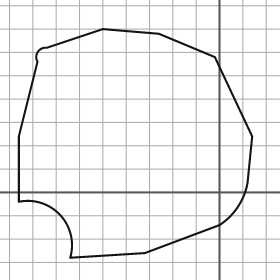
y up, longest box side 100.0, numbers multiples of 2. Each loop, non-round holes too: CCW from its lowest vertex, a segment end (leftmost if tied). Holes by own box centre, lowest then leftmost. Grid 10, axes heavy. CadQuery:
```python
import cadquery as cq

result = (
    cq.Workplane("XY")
    .moveTo(-64.0, -28.0)
    .lineTo(-32.0, -26.0)
    .lineTo(0.0, -14.0)
    .threePointArc((8.0, -6.0), (12.0, 4.0))
    .lineTo(14.0, 24.0)
    .lineTo(-2.0, 58.0)
    .lineTo(-26.0, 68.0)
    .lineTo(-50.0, 70.0)
    .lineTo(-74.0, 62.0)
    .threePointArc((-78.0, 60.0), (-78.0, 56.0))
    .lineTo(-86.0, 24.0)
    .lineTo(-86.0, -4.0)
    .threePointArc((-68.0, -10.0), (-64.0, -28.0))
    .close()
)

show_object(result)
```